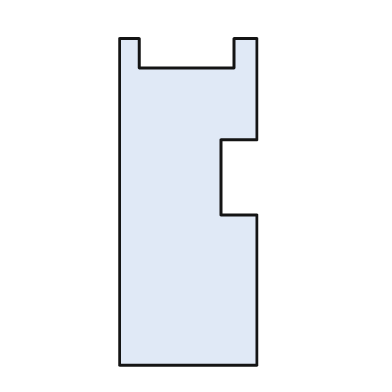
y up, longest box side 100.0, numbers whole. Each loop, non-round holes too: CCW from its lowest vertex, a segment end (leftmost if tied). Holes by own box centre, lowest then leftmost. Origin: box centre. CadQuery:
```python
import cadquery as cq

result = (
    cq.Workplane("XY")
    .moveTo(-21.0, -50.0)
    .lineTo(21.0, -50.0)
    .lineTo(21.0, -4.0)
    .lineTo(10.0, -4.0)
    .lineTo(10.0, 19.0)
    .lineTo(21.0, 19.0)
    .lineTo(21.0, 50.0)
    .lineTo(14.0, 50.0)
    .lineTo(14.0, 41.0)
    .lineTo(-15.0, 41.0)
    .lineTo(-15.0, 50.0)
    .lineTo(-21.0, 50.0)
    .close()
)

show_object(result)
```